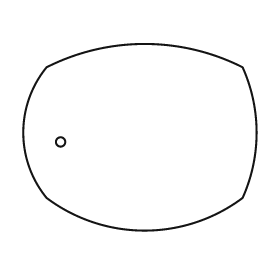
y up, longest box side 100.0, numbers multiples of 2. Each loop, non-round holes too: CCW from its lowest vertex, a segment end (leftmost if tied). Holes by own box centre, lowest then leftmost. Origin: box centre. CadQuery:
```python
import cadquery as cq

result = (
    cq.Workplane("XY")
    .moveTo(-40.0, -26.0)
    .threePointArc((2.0, -40.0), (44.0, -26.0))
    .threePointArc((50.0, 2.0), (44.0, 30.0))
    .threePointArc((2.0, 40.0), (-40.0, 30.0))
    .threePointArc((-50.0, 2.0), (-40.0, -26.0))
    .close()
    .moveTo(-34.0, -2.0)
    .circle(2.0)
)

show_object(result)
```